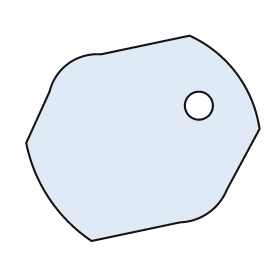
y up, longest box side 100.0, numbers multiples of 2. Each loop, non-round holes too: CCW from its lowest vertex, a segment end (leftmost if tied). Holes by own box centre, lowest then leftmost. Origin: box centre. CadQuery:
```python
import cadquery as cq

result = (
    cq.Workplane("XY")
    .moveTo(-22.0, -44.0)
    .lineTo(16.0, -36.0)
    .threePointArc((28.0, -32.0), (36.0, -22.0))
    .lineTo(50.0, 4.0)
    .threePointArc((40.0, 28.0), (20.0, 44.0))
    .lineTo(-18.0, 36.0)
    .threePointArc((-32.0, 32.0), (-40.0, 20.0))
    .lineTo(-50.0, -2.0)
    .threePointArc((-40.0, -26.0), (-22.0, -44.0))
    .close()
    .moveTo(24.0, 14.0)
    .circle(6.0)
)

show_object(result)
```